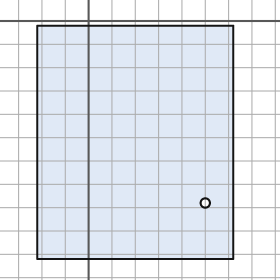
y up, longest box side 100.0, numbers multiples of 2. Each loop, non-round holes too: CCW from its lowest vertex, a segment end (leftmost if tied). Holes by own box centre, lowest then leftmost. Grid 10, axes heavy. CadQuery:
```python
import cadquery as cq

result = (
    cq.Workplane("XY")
    .moveTo(-22.0, -102.0)
    .lineTo(62.0, -102.0)
    .lineTo(62.0, -2.0)
    .lineTo(-22.0, -2.0)
    .close()
    .moveTo(50.0, -78.0)
    .circle(2.0)
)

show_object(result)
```